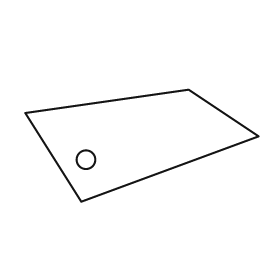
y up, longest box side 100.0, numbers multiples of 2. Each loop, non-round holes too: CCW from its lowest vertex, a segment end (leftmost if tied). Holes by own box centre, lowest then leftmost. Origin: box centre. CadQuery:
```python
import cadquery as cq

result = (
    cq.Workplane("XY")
    .moveTo(-26.0, -24.0)
    .lineTo(50.0, 4.0)
    .lineTo(20.0, 24.0)
    .lineTo(-50.0, 14.0)
    .close()
    .moveTo(-24.0, -6.0)
    .circle(4.0)
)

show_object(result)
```